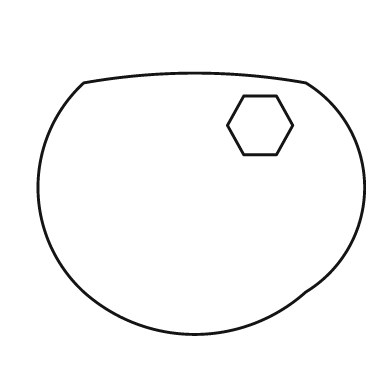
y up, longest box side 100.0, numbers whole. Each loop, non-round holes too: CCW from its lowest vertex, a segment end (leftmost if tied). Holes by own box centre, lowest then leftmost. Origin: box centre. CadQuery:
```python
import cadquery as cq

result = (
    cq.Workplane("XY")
    .moveTo(-36.0, -27.0)
    .threePointArc((-2.0, -40.0), (32.0, -27.0))
    .threePointArc((50.0, 5.0), (32.0, 37.0))
    .threePointArc((-2.0, 40.0), (-36.0, 37.0))
    .threePointArc((-50.0, 5.0), (-36.0, -27.0))
    .close()
    .moveTo(13.0, 15.0)
    .lineTo(23.0, 15.0)
    .lineTo(28.0, 24.0)
    .lineTo(23.0, 33.0)
    .lineTo(13.0, 33.0)
    .lineTo(8.0, 24.0)
    .close()
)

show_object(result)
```